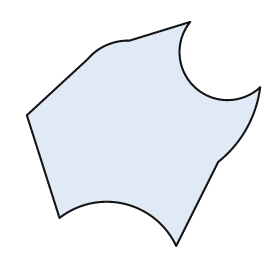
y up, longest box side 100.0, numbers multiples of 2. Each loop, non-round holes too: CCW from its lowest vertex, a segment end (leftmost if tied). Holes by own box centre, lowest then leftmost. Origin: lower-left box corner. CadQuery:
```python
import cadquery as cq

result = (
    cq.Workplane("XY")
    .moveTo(64.0, 0.0)
    .lineTo(82.0, 36.0)
    .threePointArc((94.0, 50.0), (100.0, 68.0))
    .threePointArc((72.0, 68.0), (70.0, 96.0))
    .lineTo(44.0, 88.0)
    .threePointArc((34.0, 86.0), (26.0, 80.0))
    .lineTo(0.0, 56.0)
    .lineTo(14.0, 12.0)
    .threePointArc((42.0, 18.0), (64.0, 0.0))
    .close()
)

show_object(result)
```